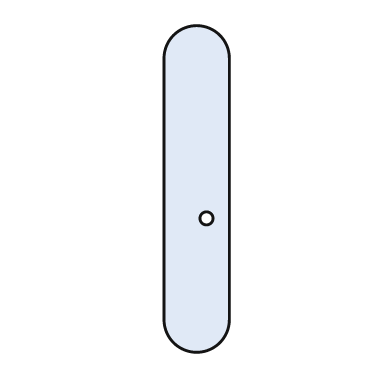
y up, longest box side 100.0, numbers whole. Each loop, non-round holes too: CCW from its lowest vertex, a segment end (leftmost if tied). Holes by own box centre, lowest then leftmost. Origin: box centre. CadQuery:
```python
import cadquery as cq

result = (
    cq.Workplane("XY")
    .moveTo(-10.0, -40.0)
    .threePointArc((0.0, -50.0), (10.0, -40.0))
    .lineTo(10.0, 40.0)
    .threePointArc((0.0, 50.0), (-10.0, 40.0))
    .close()
    .moveTo(3.0, -9.0)
    .circle(2.0)
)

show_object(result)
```